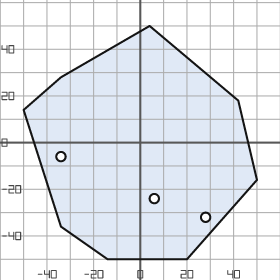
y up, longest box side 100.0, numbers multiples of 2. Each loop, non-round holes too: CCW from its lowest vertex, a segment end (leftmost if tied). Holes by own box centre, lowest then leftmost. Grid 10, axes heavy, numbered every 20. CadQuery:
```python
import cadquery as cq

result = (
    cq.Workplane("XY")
    .moveTo(-14.0, -50.0)
    .lineTo(20.0, -50.0)
    .lineTo(50.0, -16.0)
    .lineTo(42.0, 18.0)
    .lineTo(4.0, 50.0)
    .lineTo(-34.0, 28.0)
    .lineTo(-50.0, 14.0)
    .lineTo(-34.0, -36.0)
    .close()
    .moveTo(28.0, -32.0)
    .circle(2.0)
    .moveTo(6.0, -24.0)
    .circle(2.0)
    .moveTo(-34.0, -6.0)
    .circle(2.0)
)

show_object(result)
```